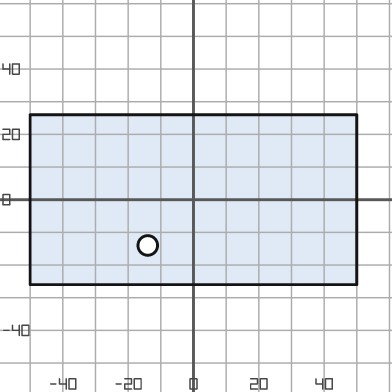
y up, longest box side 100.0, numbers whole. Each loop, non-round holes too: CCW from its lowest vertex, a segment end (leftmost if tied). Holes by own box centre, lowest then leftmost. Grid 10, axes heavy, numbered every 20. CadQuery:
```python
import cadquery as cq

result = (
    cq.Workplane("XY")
    .moveTo(-50.0, -26.0)
    .lineTo(50.0, -26.0)
    .lineTo(50.0, 26.0)
    .lineTo(-50.0, 26.0)
    .close()
    .moveTo(-14.0, -14.0)
    .circle(3.0)
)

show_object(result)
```